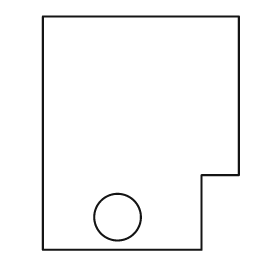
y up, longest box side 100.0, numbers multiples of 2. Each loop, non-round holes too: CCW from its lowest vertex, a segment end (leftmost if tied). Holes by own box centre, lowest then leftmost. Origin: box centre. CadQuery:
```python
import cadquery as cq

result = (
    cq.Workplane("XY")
    .moveTo(-42.0, -50.0)
    .lineTo(26.0, -50.0)
    .lineTo(26.0, -18.0)
    .lineTo(42.0, -18.0)
    .lineTo(42.0, 50.0)
    .lineTo(-42.0, 50.0)
    .close()
    .moveTo(-10.0, -36.0)
    .circle(10.0)
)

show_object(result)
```